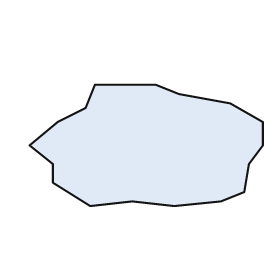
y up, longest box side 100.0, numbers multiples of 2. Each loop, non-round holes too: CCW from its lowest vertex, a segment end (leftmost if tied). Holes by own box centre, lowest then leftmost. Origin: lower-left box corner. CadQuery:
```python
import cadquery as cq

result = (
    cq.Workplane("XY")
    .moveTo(26.0, 0.0)
    .lineTo(44.0, 2.0)
    .lineTo(62.0, 0.0)
    .lineTo(82.0, 2.0)
    .lineTo(92.0, 6.0)
    .lineTo(94.0, 18.0)
    .lineTo(100.0, 26.0)
    .lineTo(100.0, 36.0)
    .lineTo(86.0, 44.0)
    .lineTo(64.0, 48.0)
    .lineTo(54.0, 52.0)
    .lineTo(28.0, 52.0)
    .lineTo(24.0, 42.0)
    .lineTo(12.0, 36.0)
    .lineTo(0.0, 26.0)
    .lineTo(10.0, 18.0)
    .lineTo(10.0, 10.0)
    .close()
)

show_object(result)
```